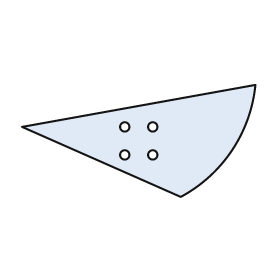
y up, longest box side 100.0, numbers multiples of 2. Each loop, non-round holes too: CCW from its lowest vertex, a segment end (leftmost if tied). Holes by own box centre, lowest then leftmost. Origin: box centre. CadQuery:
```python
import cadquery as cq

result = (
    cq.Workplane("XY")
    .moveTo(18.0, -24.0)
    .threePointArc((40.0, -4.0), (50.0, 24.0))
    .lineTo(-50.0, 6.0)
    .close()
    .moveTo(-6.0, -6.0)
    .circle(2.0)
    .moveTo(6.0, -6.0)
    .circle(2.0)
    .moveTo(-6.0, 6.0)
    .circle(2.0)
    .moveTo(6.0, 6.0)
    .circle(2.0)
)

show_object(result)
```